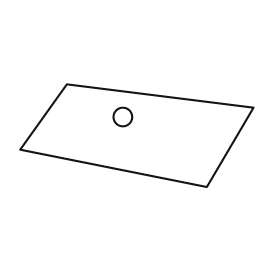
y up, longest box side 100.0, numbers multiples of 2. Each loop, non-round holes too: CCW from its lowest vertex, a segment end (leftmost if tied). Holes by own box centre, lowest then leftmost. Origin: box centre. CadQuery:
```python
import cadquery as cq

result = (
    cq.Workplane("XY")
    .moveTo(30.0, -22.0)
    .lineTo(50.0, 12.0)
    .lineTo(-30.0, 22.0)
    .lineTo(-50.0, -6.0)
    .close()
    .moveTo(-6.0, 8.0)
    .circle(4.0)
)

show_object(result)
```